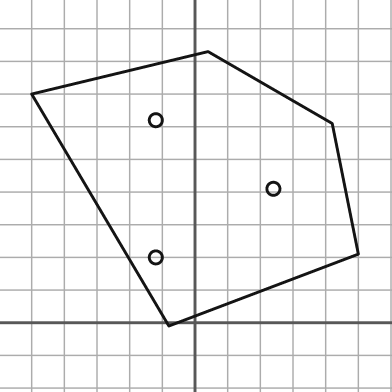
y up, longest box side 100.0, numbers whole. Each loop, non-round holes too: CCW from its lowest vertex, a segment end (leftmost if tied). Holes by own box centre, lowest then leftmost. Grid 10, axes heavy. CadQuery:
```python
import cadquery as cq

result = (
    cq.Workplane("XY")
    .moveTo(-8.0, -1.0)
    .lineTo(50.0, 21.0)
    .lineTo(42.0, 61.0)
    .lineTo(4.0, 83.0)
    .lineTo(-50.0, 70.0)
    .close()
    .moveTo(-12.0, 20.0)
    .circle(2.0)
    .moveTo(24.0, 41.0)
    .circle(2.0)
    .moveTo(-12.0, 62.0)
    .circle(2.0)
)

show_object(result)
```